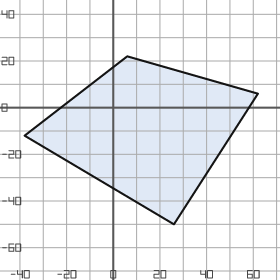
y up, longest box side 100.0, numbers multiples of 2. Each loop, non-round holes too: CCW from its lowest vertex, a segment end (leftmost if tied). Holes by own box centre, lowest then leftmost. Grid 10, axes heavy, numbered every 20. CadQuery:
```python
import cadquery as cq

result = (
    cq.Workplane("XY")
    .moveTo(26.0, -50.0)
    .lineTo(62.0, 6.0)
    .lineTo(6.0, 22.0)
    .lineTo(-38.0, -12.0)
    .close()
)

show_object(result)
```